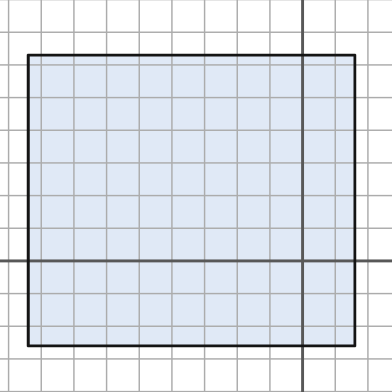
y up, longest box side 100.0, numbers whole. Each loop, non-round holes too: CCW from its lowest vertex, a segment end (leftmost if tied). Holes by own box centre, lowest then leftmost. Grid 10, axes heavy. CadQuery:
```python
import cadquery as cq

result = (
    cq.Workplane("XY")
    .moveTo(-84.0, -26.0)
    .lineTo(16.0, -26.0)
    .lineTo(16.0, 63.0)
    .lineTo(-84.0, 63.0)
    .close()
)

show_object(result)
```